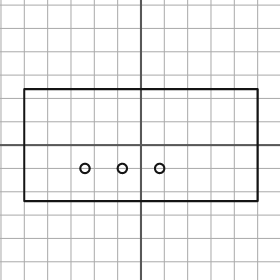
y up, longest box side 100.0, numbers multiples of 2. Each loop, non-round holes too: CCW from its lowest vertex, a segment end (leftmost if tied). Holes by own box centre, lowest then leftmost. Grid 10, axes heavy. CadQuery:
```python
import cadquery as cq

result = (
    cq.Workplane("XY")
    .moveTo(-50.0, -24.0)
    .lineTo(50.0, -24.0)
    .lineTo(50.0, 24.0)
    .lineTo(-50.0, 24.0)
    .close()
    .moveTo(-24.0, -10.0)
    .circle(2.0)
    .moveTo(-8.0, -10.0)
    .circle(2.0)
    .moveTo(8.0, -10.0)
    .circle(2.0)
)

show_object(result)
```